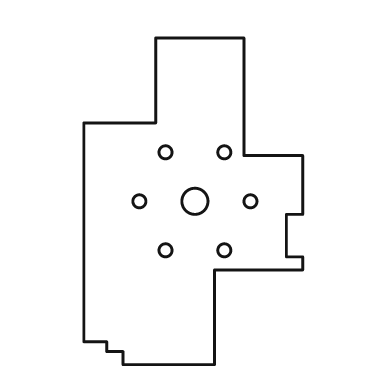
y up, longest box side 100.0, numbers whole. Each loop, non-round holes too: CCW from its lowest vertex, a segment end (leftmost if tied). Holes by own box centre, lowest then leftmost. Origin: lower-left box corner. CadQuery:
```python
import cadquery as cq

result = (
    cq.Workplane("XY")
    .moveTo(12.0, 0.0)
    .lineTo(40.0, 0.0)
    .lineTo(40.0, 29.0)
    .lineTo(67.0, 29.0)
    .lineTo(67.0, 33.0)
    .lineTo(62.0, 33.0)
    .lineTo(62.0, 46.0)
    .lineTo(67.0, 46.0)
    .lineTo(67.0, 64.0)
    .lineTo(49.0, 64.0)
    .lineTo(49.0, 100.0)
    .lineTo(22.0, 100.0)
    .lineTo(22.0, 74.0)
    .lineTo(0.0, 74.0)
    .lineTo(0.0, 7.0)
    .lineTo(7.0, 7.0)
    .lineTo(7.0, 4.0)
    .lineTo(12.0, 4.0)
    .close()
    .moveTo(25.0, 35.0)
    .circle(2.0)
    .moveTo(43.0, 35.0)
    .circle(2.0)
    .moveTo(17.0, 50.0)
    .circle(2.0)
    .moveTo(34.0, 50.0)
    .circle(4.0)
    .moveTo(51.0, 50.0)
    .circle(2.0)
    .moveTo(25.0, 65.0)
    .circle(2.0)
    .moveTo(43.0, 65.0)
    .circle(2.0)
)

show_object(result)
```